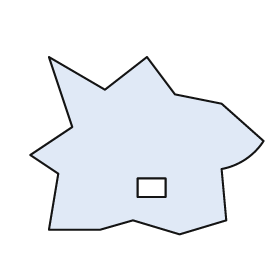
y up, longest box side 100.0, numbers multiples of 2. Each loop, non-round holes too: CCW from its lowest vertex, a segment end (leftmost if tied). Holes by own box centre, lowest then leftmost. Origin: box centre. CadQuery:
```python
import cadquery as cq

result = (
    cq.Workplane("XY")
    .moveTo(14.0, -38.0)
    .lineTo(34.0, -32.0)
    .lineTo(32.0, -10.0)
    .threePointArc((42.0, -6.0), (50.0, 2.0))
    .lineTo(32.0, 18.0)
    .lineTo(12.0, 22.0)
    .lineTo(0.0, 38.0)
    .lineTo(-18.0, 24.0)
    .lineTo(-42.0, 38.0)
    .lineTo(-32.0, 8.0)
    .lineTo(-50.0, -4.0)
    .lineTo(-38.0, -12.0)
    .lineTo(-42.0, -36.0)
    .lineTo(-20.0, -36.0)
    .lineTo(-6.0, -32.0)
    .close()
    .moveTo(-4.0, -22.0)
    .lineTo(8.0, -22.0)
    .lineTo(8.0, -14.0)
    .lineTo(-4.0, -14.0)
    .close()
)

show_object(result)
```